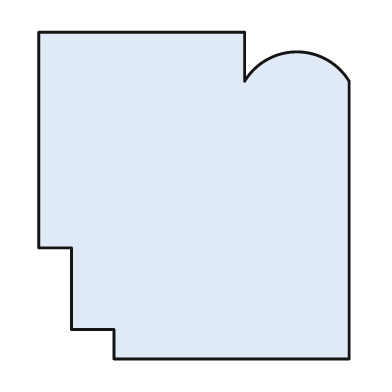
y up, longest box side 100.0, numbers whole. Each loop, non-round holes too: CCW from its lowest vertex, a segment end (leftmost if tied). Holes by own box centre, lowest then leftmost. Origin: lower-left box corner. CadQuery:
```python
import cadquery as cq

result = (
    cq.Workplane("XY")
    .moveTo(23.0, 0.0)
    .lineTo(95.0, 0.0)
    .lineTo(95.0, 85.0)
    .threePointArc((79.0, 94.0), (63.0, 85.0))
    .lineTo(63.0, 100.0)
    .lineTo(0.0, 100.0)
    .lineTo(0.0, 34.0)
    .lineTo(10.0, 34.0)
    .lineTo(10.0, 9.0)
    .lineTo(23.0, 9.0)
    .close()
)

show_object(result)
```